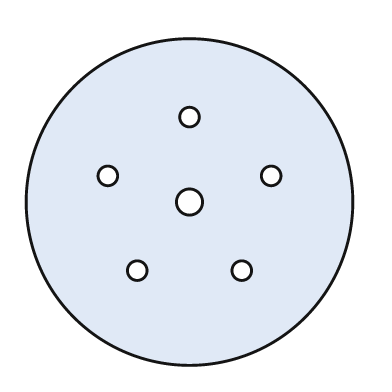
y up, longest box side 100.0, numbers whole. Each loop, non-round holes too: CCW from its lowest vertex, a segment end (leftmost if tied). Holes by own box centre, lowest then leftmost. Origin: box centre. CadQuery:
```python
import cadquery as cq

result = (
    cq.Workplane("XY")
    .moveTo(0.0, 0.0)
    .circle(50.0)
    .moveTo(-16.0, -21.0)
    .circle(3.0)
    .moveTo(16.0, -21.0)
    .circle(3.0)
    .moveTo(0.0, 0.0)
    .circle(4.0)
    .moveTo(-25.0, 8.0)
    .circle(3.0)
    .moveTo(25.0, 8.0)
    .circle(3.0)
    .moveTo(0.0, 26.0)
    .circle(3.0)
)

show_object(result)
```